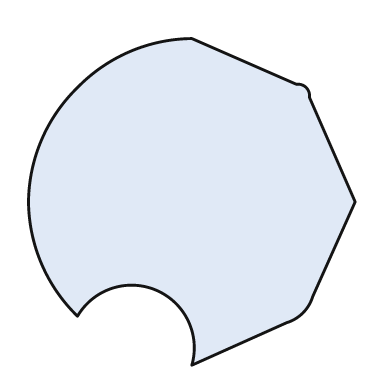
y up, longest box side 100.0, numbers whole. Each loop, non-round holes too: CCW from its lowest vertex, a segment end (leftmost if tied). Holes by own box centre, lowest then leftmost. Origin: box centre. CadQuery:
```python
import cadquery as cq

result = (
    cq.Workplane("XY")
    .moveTo(0.0, -50.0)
    .lineTo(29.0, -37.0)
    .threePointArc((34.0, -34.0), (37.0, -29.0))
    .lineTo(50.0, 0.0)
    .lineTo(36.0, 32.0)
    .threePointArc((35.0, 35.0), (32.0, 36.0))
    .lineTo(0.0, 50.0)
    .threePointArc((-19.0, 46.0), (-35.0, 35.0))
    .threePointArc((-46.0, 19.0), (-50.0, 0.0))
    .threePointArc((-46.0, -19.0), (-35.0, -35.0))
    .threePointArc((-11.0, -27.0), (0.0, -50.0))
    .close()
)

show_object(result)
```